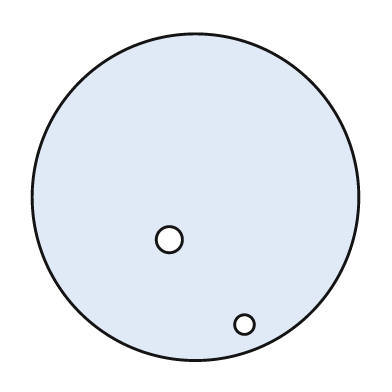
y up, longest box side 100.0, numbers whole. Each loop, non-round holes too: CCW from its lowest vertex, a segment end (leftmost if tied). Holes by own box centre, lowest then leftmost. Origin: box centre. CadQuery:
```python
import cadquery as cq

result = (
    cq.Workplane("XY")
    .moveTo(0.0, 0.0)
    .circle(50.0)
    .moveTo(15.0, -39.0)
    .circle(3.0)
    .moveTo(-8.0, -13.0)
    .circle(4.0)
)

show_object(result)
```